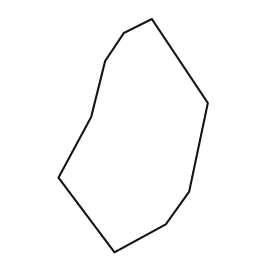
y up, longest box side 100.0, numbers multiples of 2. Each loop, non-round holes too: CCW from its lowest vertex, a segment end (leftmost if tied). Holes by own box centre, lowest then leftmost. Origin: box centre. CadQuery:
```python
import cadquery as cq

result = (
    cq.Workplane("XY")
    .moveTo(-8.0, -50.0)
    .lineTo(14.0, -38.0)
    .lineTo(24.0, -24.0)
    .lineTo(32.0, 14.0)
    .lineTo(8.0, 50.0)
    .lineTo(-4.0, 44.0)
    .lineTo(-12.0, 32.0)
    .lineTo(-18.0, 8.0)
    .lineTo(-32.0, -18.0)
    .close()
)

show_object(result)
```